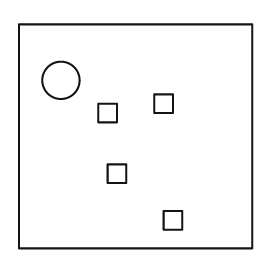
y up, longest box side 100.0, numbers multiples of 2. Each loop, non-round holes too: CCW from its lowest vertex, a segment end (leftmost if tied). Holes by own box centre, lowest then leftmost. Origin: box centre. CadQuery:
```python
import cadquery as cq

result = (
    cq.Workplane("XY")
    .moveTo(-50.0, -48.0)
    .lineTo(50.0, -48.0)
    .lineTo(50.0, 48.0)
    .lineTo(-50.0, 48.0)
    .close()
    .moveTo(12.0, -40.0)
    .lineTo(20.0, -40.0)
    .lineTo(20.0, -32.0)
    .lineTo(12.0, -32.0)
    .close()
    .moveTo(-12.0, -20.0)
    .lineTo(-4.0, -20.0)
    .lineTo(-4.0, -12.0)
    .lineTo(-12.0, -12.0)
    .close()
    .moveTo(-16.0, 6.0)
    .lineTo(-8.0, 6.0)
    .lineTo(-8.0, 14.0)
    .lineTo(-16.0, 14.0)
    .close()
    .moveTo(8.0, 10.0)
    .lineTo(16.0, 10.0)
    .lineTo(16.0, 18.0)
    .lineTo(8.0, 18.0)
    .close()
    .moveTo(-32.0, 24.0)
    .circle(8.0)
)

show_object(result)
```